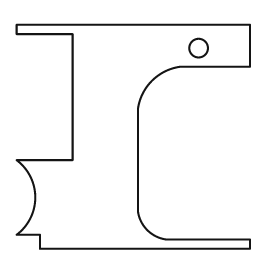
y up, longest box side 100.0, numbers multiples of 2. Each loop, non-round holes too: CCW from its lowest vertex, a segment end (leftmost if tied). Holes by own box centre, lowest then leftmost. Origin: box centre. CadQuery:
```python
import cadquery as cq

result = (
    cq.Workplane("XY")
    .moveTo(-40.0, -48.0)
    .lineTo(50.0, -48.0)
    .lineTo(50.0, -44.0)
    .lineTo(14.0, -44.0)
    .threePointArc((6.0, -40.0), (2.0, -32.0))
    .lineTo(2.0, 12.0)
    .threePointArc((8.0, 24.0), (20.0, 30.0))
    .lineTo(50.0, 30.0)
    .lineTo(50.0, 48.0)
    .lineTo(-50.0, 48.0)
    .lineTo(-50.0, 44.0)
    .lineTo(-26.0, 44.0)
    .lineTo(-26.0, -10.0)
    .lineTo(-50.0, -10.0)
    .threePointArc((-42.0, -26.0), (-50.0, -42.0))
    .lineTo(-40.0, -42.0)
    .close()
    .moveTo(28.0, 38.0)
    .circle(4.0)
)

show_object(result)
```